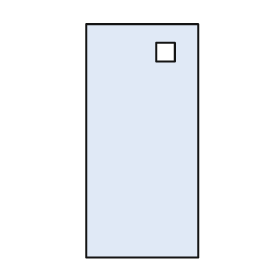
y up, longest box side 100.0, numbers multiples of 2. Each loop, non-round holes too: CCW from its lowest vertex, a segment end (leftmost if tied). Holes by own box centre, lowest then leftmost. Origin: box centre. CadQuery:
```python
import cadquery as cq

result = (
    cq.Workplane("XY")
    .moveTo(-24.0, -50.0)
    .lineTo(24.0, -50.0)
    .lineTo(24.0, 50.0)
    .lineTo(-24.0, 50.0)
    .close()
    .moveTo(6.0, 34.0)
    .lineTo(14.0, 34.0)
    .lineTo(14.0, 42.0)
    .lineTo(6.0, 42.0)
    .close()
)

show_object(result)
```